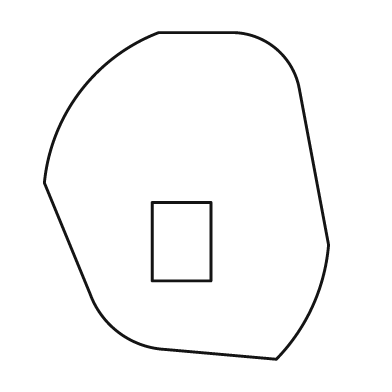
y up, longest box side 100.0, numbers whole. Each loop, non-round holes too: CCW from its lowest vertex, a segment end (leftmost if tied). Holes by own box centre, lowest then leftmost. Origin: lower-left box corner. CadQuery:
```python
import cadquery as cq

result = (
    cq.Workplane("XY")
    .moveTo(71.0, 0.0)
    .threePointArc((82.0, 16.0), (87.0, 35.0))
    .lineTo(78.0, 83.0)
    .threePointArc((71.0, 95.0), (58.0, 100.0))
    .lineTo(35.0, 100.0)
    .threePointArc((11.0, 82.0), (0.0, 54.0))
    .lineTo(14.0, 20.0)
    .threePointArc((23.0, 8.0), (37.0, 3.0))
    .close()
    .moveTo(33.0, 24.0)
    .lineTo(51.0, 24.0)
    .lineTo(51.0, 48.0)
    .lineTo(33.0, 48.0)
    .close()
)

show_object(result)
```